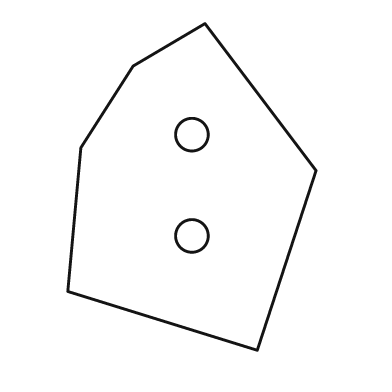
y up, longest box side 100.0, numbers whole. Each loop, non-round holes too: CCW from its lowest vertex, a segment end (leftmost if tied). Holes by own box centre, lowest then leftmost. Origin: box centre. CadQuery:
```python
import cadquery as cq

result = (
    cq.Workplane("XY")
    .moveTo(20.0, -50.0)
    .lineTo(38.0, 5.0)
    .lineTo(4.0, 50.0)
    .lineTo(-18.0, 37.0)
    .lineTo(-34.0, 12.0)
    .lineTo(-38.0, -32.0)
    .close()
    .moveTo(0.0, -15.0)
    .circle(5.0)
    .moveTo(0.0, 16.0)
    .circle(5.0)
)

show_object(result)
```